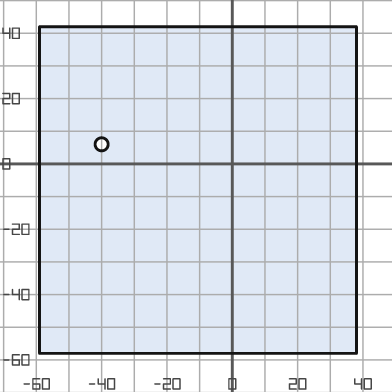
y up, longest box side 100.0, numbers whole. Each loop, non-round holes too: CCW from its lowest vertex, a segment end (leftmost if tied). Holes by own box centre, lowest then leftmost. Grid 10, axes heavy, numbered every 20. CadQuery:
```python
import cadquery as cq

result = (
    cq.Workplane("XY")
    .moveTo(-59.0, -58.0)
    .lineTo(38.0, -58.0)
    .lineTo(38.0, 42.0)
    .lineTo(-59.0, 42.0)
    .close()
    .moveTo(-40.0, 6.0)
    .circle(2.0)
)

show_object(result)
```